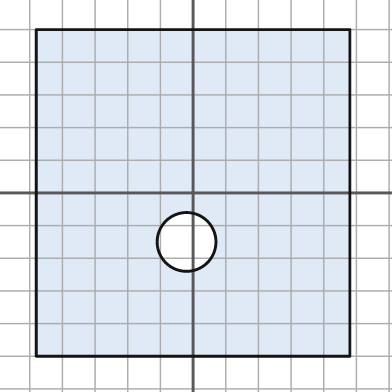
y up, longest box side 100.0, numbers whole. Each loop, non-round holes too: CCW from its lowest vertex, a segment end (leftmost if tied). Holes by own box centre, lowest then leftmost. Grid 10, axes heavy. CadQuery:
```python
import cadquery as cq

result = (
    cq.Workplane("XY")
    .moveTo(-48.0, -50.0)
    .lineTo(48.0, -50.0)
    .lineTo(48.0, 50.0)
    .lineTo(-48.0, 50.0)
    .close()
    .moveTo(-2.0, -15.0)
    .circle(9.0)
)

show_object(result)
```